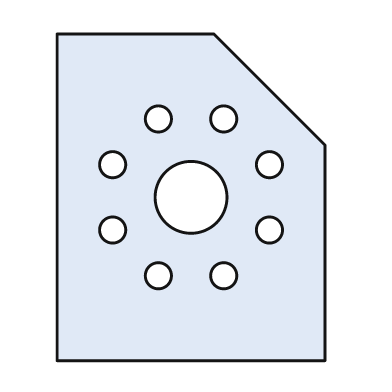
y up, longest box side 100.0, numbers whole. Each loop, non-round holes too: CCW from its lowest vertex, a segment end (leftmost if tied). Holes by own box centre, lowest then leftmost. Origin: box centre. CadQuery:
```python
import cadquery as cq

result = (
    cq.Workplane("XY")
    .moveTo(-41.0, -50.0)
    .lineTo(41.0, -50.0)
    .lineTo(41.0, 16.0)
    .lineTo(7.0, 50.0)
    .lineTo(-41.0, 50.0)
    .close()
    .moveTo(-10.0, -24.0)
    .circle(4.0)
    .moveTo(10.0, -24.0)
    .circle(4.0)
    .moveTo(-24.0, -10.0)
    .circle(4.0)
    .moveTo(24.0, -10.0)
    .circle(4.0)
    .moveTo(0.0, 0.0)
    .circle(11.0)
    .moveTo(-24.0, 10.0)
    .circle(4.0)
    .moveTo(24.0, 10.0)
    .circle(4.0)
    .moveTo(-10.0, 24.0)
    .circle(4.0)
    .moveTo(10.0, 24.0)
    .circle(4.0)
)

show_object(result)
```